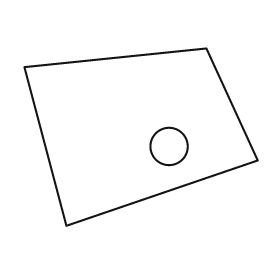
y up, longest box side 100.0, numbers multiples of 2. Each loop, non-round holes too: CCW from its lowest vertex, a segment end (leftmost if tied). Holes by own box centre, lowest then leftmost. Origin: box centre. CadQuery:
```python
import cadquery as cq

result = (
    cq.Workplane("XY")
    .moveTo(-32.0, -38.0)
    .lineTo(50.0, -10.0)
    .lineTo(28.0, 38.0)
    .lineTo(-50.0, 30.0)
    .close()
    .moveTo(12.0, -4.0)
    .circle(8.0)
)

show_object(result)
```